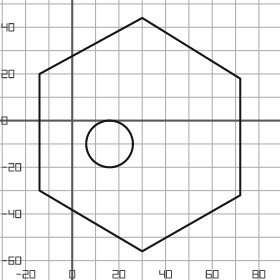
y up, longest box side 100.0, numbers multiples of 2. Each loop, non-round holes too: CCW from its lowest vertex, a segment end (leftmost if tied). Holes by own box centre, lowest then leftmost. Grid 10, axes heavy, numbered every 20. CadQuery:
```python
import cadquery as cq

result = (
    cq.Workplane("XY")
    .moveTo(30.0, -56.0)
    .lineTo(72.0, -32.0)
    .lineTo(72.0, 18.0)
    .lineTo(30.0, 44.0)
    .lineTo(-14.0, 20.0)
    .lineTo(-14.0, -30.0)
    .close()
    .moveTo(16.0, -10.0)
    .circle(10.0)
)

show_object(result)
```